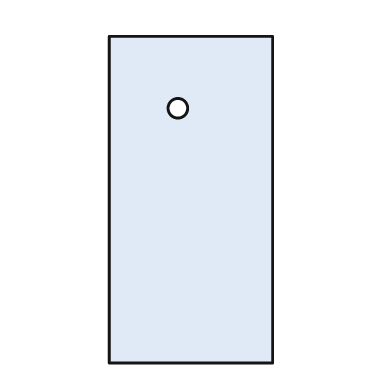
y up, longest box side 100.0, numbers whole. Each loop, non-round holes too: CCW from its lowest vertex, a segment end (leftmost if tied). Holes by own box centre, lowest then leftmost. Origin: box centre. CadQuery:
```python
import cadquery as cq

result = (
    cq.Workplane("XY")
    .moveTo(-25.0, -50.0)
    .lineTo(25.0, -50.0)
    .lineTo(25.0, 50.0)
    .lineTo(-25.0, 50.0)
    .close()
    .moveTo(-4.0, 28.0)
    .circle(3.0)
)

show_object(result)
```